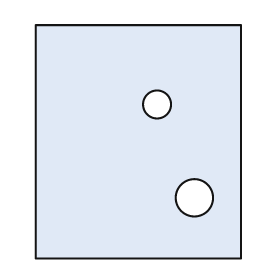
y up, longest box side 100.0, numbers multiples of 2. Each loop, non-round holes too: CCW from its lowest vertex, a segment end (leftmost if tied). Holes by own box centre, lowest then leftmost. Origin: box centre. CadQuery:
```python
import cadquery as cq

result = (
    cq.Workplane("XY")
    .moveTo(-44.0, -50.0)
    .lineTo(44.0, -50.0)
    .lineTo(44.0, 50.0)
    .lineTo(-44.0, 50.0)
    .close()
    .moveTo(24.0, -24.0)
    .circle(8.0)
    .moveTo(8.0, 16.0)
    .circle(6.0)
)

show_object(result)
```